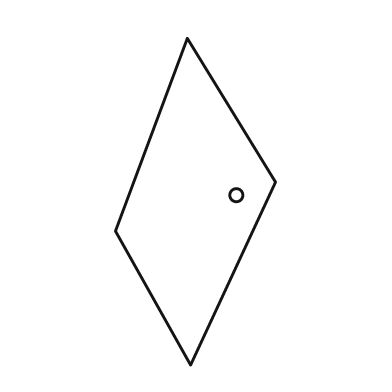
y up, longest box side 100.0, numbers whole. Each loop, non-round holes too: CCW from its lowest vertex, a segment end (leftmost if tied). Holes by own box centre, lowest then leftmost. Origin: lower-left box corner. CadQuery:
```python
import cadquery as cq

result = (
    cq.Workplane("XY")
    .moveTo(23.0, 0.0)
    .lineTo(49.0, 56.0)
    .lineTo(22.0, 100.0)
    .lineTo(0.0, 41.0)
    .close()
    .moveTo(37.0, 52.0)
    .circle(2.0)
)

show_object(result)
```